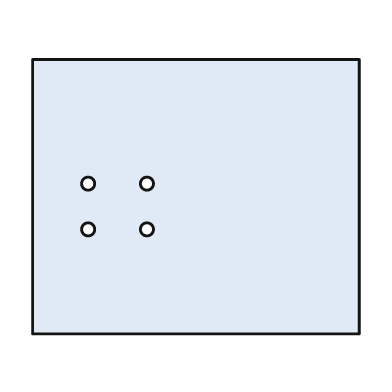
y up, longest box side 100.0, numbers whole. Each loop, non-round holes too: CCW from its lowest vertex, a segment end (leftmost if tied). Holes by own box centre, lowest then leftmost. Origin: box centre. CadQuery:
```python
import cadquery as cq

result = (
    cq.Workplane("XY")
    .moveTo(-50.0, -42.0)
    .lineTo(50.0, -42.0)
    .lineTo(50.0, 42.0)
    .lineTo(-50.0, 42.0)
    .close()
    .moveTo(-33.0, -10.0)
    .circle(2.0)
    .moveTo(-15.0, -10.0)
    .circle(2.0)
    .moveTo(-33.0, 4.0)
    .circle(2.0)
    .moveTo(-15.0, 4.0)
    .circle(2.0)
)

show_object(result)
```